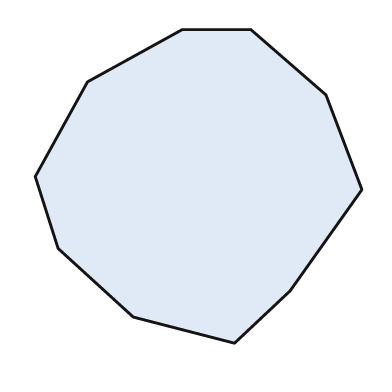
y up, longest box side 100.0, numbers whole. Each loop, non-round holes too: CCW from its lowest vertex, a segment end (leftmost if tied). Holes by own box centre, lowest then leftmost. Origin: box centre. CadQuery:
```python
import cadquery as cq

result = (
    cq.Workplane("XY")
    .moveTo(11.0, -48.0)
    .lineTo(28.0, -32.0)
    .lineTo(50.0, -1.0)
    .lineTo(39.0, 28.0)
    .lineTo(16.0, 48.0)
    .lineTo(-5.0, 48.0)
    .lineTo(-34.0, 32.0)
    .lineTo(-50.0, 3.0)
    .lineTo(-43.0, -19.0)
    .lineTo(-20.0, -40.0)
    .close()
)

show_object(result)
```